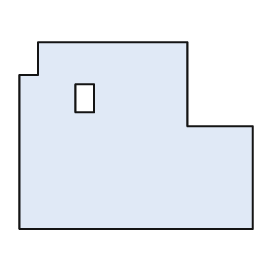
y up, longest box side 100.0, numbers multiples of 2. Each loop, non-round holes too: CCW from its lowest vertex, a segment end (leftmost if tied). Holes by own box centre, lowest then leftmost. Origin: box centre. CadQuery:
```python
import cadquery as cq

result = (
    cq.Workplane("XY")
    .moveTo(-50.0, -40.0)
    .lineTo(50.0, -40.0)
    .lineTo(50.0, 4.0)
    .lineTo(22.0, 4.0)
    .lineTo(22.0, 40.0)
    .lineTo(-42.0, 40.0)
    .lineTo(-42.0, 26.0)
    .lineTo(-50.0, 26.0)
    .close()
    .moveTo(-26.0, 10.0)
    .lineTo(-18.0, 10.0)
    .lineTo(-18.0, 22.0)
    .lineTo(-26.0, 22.0)
    .close()
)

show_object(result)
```